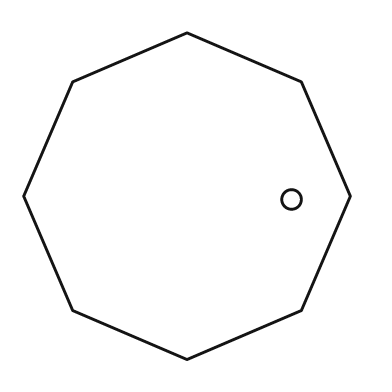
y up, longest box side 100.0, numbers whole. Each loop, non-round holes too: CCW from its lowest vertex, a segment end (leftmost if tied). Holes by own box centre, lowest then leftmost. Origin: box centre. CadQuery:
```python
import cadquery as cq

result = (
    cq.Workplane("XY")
    .moveTo(0.0, -50.0)
    .lineTo(35.0, -35.0)
    .lineTo(50.0, 0.0)
    .lineTo(35.0, 35.0)
    .lineTo(0.0, 50.0)
    .lineTo(-35.0, 35.0)
    .lineTo(-50.0, 0.0)
    .lineTo(-35.0, -35.0)
    .close()
    .moveTo(32.0, -1.0)
    .circle(3.0)
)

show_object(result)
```